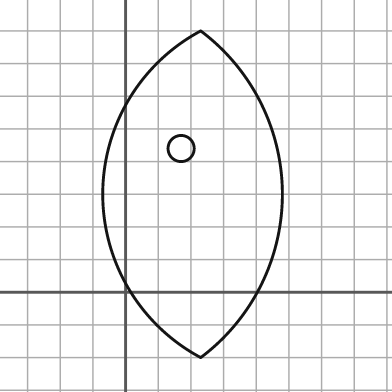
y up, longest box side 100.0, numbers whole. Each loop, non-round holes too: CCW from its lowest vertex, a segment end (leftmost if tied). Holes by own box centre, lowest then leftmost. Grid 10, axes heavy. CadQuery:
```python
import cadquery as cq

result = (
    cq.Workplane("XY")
    .moveTo(23.0, -20.0)
    .threePointArc((48.0, 30.0), (23.0, 80.0))
    .threePointArc((-7.0, 30.0), (23.0, -20.0))
    .close()
    .moveTo(17.0, 44.0)
    .circle(4.0)
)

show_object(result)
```